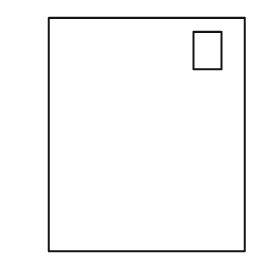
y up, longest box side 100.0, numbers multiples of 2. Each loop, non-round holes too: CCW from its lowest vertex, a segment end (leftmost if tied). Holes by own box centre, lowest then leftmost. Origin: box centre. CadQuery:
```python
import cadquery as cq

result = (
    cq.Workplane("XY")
    .moveTo(-42.0, -50.0)
    .lineTo(42.0, -50.0)
    .lineTo(42.0, 50.0)
    .lineTo(-42.0, 50.0)
    .close()
    .moveTo(20.0, 28.0)
    .lineTo(32.0, 28.0)
    .lineTo(32.0, 44.0)
    .lineTo(20.0, 44.0)
    .close()
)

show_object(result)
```